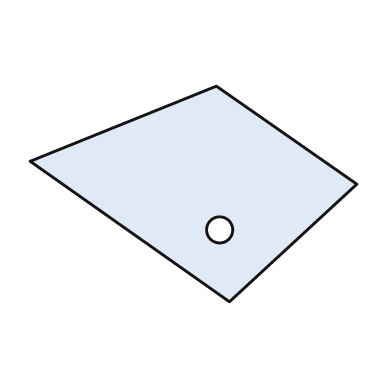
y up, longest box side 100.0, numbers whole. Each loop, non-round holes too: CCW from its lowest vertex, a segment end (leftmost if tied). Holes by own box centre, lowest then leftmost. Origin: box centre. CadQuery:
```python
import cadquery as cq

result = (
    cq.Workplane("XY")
    .moveTo(11.0, -33.0)
    .lineTo(50.0, 3.0)
    .lineTo(7.0, 33.0)
    .lineTo(-50.0, 10.0)
    .close()
    .moveTo(8.0, -11.0)
    .circle(4.0)
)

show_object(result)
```